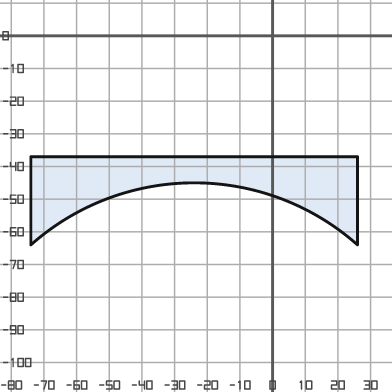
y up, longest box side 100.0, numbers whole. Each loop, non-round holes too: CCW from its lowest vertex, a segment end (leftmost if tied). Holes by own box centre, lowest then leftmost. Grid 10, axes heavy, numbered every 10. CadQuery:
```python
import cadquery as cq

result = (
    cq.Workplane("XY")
    .moveTo(-74.0, -64.0)
    .threePointArc((-24.0, -45.0), (26.0, -64.0))
    .lineTo(26.0, -37.0)
    .lineTo(-74.0, -37.0)
    .close()
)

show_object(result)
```